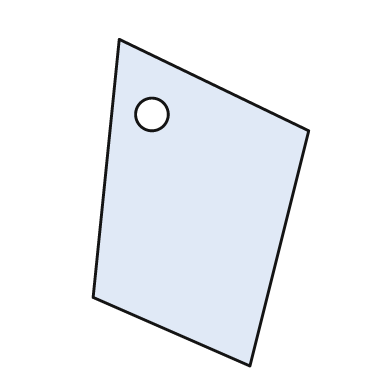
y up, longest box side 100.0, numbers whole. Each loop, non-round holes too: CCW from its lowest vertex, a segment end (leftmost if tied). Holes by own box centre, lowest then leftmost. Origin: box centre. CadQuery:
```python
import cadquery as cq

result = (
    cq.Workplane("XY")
    .moveTo(15.0, -50.0)
    .lineTo(33.0, 22.0)
    .lineTo(-25.0, 50.0)
    .lineTo(-33.0, -29.0)
    .close()
    .moveTo(-15.0, 27.0)
    .circle(5.0)
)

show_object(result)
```